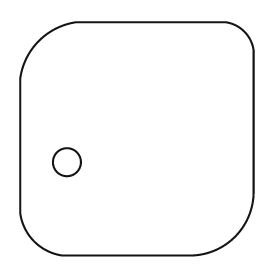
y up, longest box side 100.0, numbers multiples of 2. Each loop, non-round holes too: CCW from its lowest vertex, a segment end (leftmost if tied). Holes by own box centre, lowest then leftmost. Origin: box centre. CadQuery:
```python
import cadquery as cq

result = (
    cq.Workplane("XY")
    .moveTo(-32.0, -50.0)
    .lineTo(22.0, -50.0)
    .threePointArc((42.0, -42.0), (50.0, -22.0))
    .lineTo(50.0, 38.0)
    .threePointArc((46.0, 46.0), (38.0, 50.0))
    .lineTo(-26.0, 50.0)
    .threePointArc((-42.0, 42.0), (-50.0, 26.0))
    .lineTo(-50.0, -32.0)
    .threePointArc((-44.0, -44.0), (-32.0, -50.0))
    .close()
    .moveTo(-30.0, -10.0)
    .circle(6.0)
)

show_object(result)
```